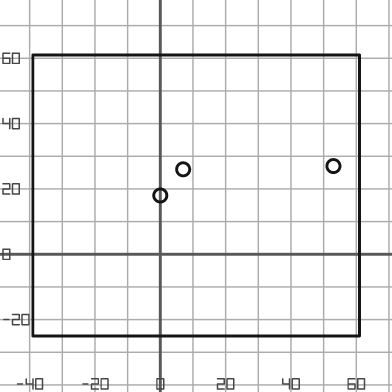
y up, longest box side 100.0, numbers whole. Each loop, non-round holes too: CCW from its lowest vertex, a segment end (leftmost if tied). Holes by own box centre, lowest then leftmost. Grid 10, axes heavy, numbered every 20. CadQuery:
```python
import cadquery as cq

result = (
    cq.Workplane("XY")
    .moveTo(-39.0, -25.0)
    .lineTo(61.0, -25.0)
    .lineTo(61.0, 61.0)
    .lineTo(-39.0, 61.0)
    .close()
    .moveTo(0.0, 18.0)
    .circle(2.0)
    .moveTo(7.0, 26.0)
    .circle(2.0)
    .moveTo(53.0, 27.0)
    .circle(2.0)
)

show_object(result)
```